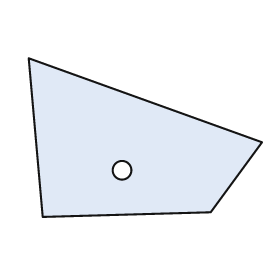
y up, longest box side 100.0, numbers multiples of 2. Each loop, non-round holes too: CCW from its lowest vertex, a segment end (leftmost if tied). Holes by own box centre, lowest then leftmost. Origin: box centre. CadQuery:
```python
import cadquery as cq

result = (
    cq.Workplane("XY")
    .moveTo(-44.0, -34.0)
    .lineTo(28.0, -32.0)
    .lineTo(50.0, -2.0)
    .lineTo(-50.0, 34.0)
    .close()
    .moveTo(-10.0, -14.0)
    .circle(4.0)
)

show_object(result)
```